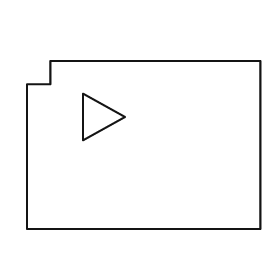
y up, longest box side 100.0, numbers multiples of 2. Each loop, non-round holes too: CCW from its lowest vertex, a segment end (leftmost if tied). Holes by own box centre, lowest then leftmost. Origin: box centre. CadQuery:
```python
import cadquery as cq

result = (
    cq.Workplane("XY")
    .moveTo(-50.0, -36.0)
    .lineTo(50.0, -36.0)
    .lineTo(50.0, 36.0)
    .lineTo(-40.0, 36.0)
    .lineTo(-40.0, 26.0)
    .lineTo(-50.0, 26.0)
    .close()
    .moveTo(-26.0, 2.0)
    .lineTo(-8.0, 12.0)
    .lineTo(-26.0, 22.0)
    .close()
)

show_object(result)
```